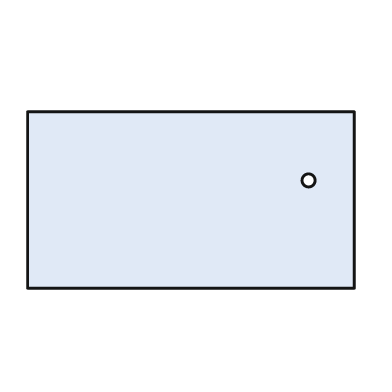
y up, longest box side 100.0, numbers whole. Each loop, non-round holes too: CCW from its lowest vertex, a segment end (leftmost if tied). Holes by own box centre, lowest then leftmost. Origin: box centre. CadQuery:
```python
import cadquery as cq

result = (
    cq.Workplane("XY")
    .moveTo(-50.0, -27.0)
    .lineTo(50.0, -27.0)
    .lineTo(50.0, 27.0)
    .lineTo(-50.0, 27.0)
    .close()
    .moveTo(36.0, 6.0)
    .circle(2.0)
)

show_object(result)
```